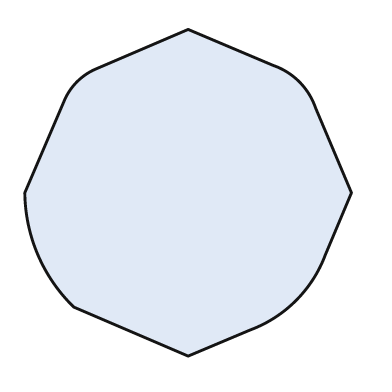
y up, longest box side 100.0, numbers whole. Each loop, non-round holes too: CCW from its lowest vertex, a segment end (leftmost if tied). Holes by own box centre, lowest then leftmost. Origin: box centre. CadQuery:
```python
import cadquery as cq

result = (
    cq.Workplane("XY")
    .moveTo(0.0, -50.0)
    .lineTo(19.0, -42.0)
    .threePointArc((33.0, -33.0), (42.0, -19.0))
    .lineTo(50.0, 0.0)
    .lineTo(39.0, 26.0)
    .threePointArc((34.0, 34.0), (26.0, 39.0))
    .lineTo(0.0, 50.0)
    .lineTo(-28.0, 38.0)
    .threePointArc((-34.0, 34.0), (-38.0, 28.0))
    .lineTo(-50.0, 0.0)
    .threePointArc((-46.0, -19.0), (-35.0, -35.0))
    .close()
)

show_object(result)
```